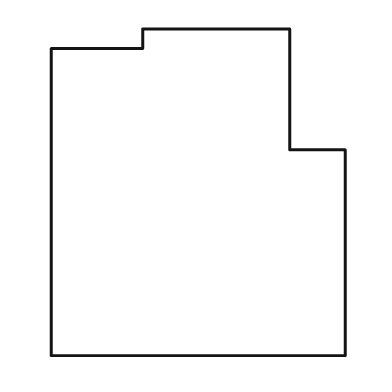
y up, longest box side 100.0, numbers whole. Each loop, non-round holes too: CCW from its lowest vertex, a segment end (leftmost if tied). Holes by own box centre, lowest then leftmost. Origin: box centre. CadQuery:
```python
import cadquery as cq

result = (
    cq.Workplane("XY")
    .moveTo(-45.0, -50.0)
    .lineTo(45.0, -50.0)
    .lineTo(45.0, 13.0)
    .lineTo(28.0, 13.0)
    .lineTo(28.0, 50.0)
    .lineTo(-17.0, 50.0)
    .lineTo(-17.0, 44.0)
    .lineTo(-45.0, 44.0)
    .close()
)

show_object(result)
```